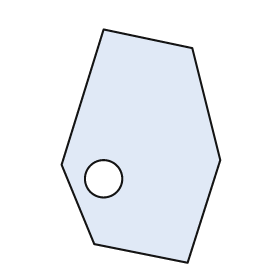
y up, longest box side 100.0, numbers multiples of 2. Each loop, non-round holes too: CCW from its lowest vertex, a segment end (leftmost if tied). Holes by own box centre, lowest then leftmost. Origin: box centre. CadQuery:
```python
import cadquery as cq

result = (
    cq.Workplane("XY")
    .moveTo(20.0, -50.0)
    .lineTo(34.0, -6.0)
    .lineTo(22.0, 42.0)
    .lineTo(-16.0, 50.0)
    .lineTo(-34.0, -8.0)
    .lineTo(-20.0, -42.0)
    .close()
    .moveTo(-16.0, -14.0)
    .circle(8.0)
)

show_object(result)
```